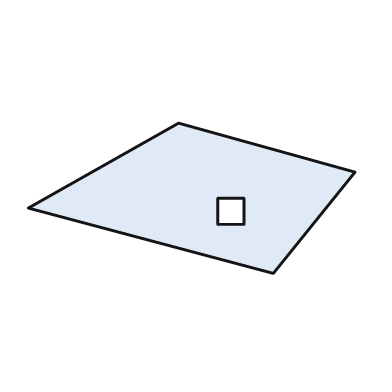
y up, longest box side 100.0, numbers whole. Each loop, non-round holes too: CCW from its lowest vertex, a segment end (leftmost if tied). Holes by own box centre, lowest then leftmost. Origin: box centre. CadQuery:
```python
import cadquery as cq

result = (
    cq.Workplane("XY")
    .moveTo(25.0, -23.0)
    .lineTo(50.0, 8.0)
    .lineTo(-4.0, 23.0)
    .lineTo(-50.0, -3.0)
    .close()
    .moveTo(8.0, -8.0)
    .lineTo(16.0, -8.0)
    .lineTo(16.0, 0.0)
    .lineTo(8.0, 0.0)
    .close()
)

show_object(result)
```